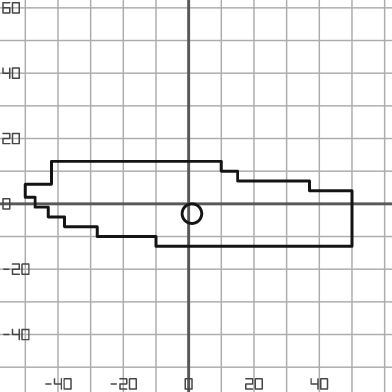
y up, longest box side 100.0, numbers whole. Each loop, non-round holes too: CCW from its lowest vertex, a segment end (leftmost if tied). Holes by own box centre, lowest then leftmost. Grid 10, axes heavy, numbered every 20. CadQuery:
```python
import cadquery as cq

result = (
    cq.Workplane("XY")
    .moveTo(-10.0, -13.0)
    .lineTo(50.0, -13.0)
    .lineTo(50.0, 4.0)
    .lineTo(37.0, 4.0)
    .lineTo(37.0, 7.0)
    .lineTo(15.0, 7.0)
    .lineTo(15.0, 10.0)
    .lineTo(10.0, 10.0)
    .lineTo(10.0, 13.0)
    .lineTo(-42.0, 13.0)
    .lineTo(-42.0, 6.0)
    .lineTo(-50.0, 6.0)
    .lineTo(-50.0, 2.0)
    .lineTo(-47.0, 2.0)
    .lineTo(-47.0, -1.0)
    .lineTo(-43.0, -1.0)
    .lineTo(-43.0, -4.0)
    .lineTo(-38.0, -4.0)
    .lineTo(-38.0, -7.0)
    .lineTo(-28.0, -7.0)
    .lineTo(-28.0, -10.0)
    .lineTo(-10.0, -10.0)
    .close()
    .moveTo(1.0, -3.0)
    .circle(3.0)
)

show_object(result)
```